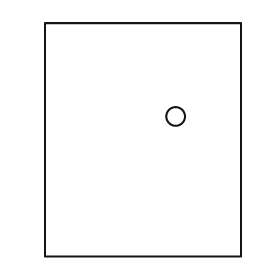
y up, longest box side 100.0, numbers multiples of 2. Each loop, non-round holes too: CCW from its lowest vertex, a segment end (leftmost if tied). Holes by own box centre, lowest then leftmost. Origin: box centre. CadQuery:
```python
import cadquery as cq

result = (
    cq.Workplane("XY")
    .moveTo(-42.0, -50.0)
    .lineTo(42.0, -50.0)
    .lineTo(42.0, 50.0)
    .lineTo(-42.0, 50.0)
    .close()
    .moveTo(14.0, 10.0)
    .circle(4.0)
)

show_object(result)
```